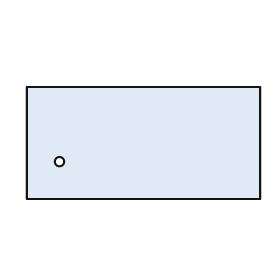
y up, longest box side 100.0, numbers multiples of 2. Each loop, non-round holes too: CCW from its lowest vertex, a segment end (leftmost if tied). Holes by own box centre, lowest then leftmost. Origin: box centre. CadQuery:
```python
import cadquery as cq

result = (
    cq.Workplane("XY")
    .moveTo(-50.0, -24.0)
    .lineTo(50.0, -24.0)
    .lineTo(50.0, 24.0)
    .lineTo(-50.0, 24.0)
    .close()
    .moveTo(-36.0, -8.0)
    .circle(2.0)
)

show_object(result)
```